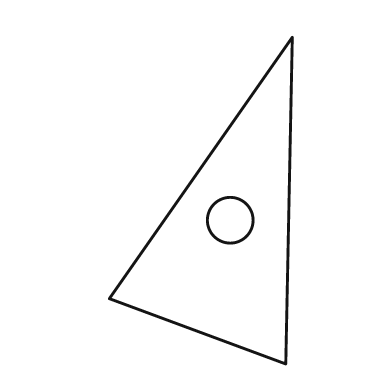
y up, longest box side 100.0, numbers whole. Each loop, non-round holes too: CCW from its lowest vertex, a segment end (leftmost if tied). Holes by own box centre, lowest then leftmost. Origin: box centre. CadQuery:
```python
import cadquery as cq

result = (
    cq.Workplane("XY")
    .moveTo(26.0, -50.0)
    .lineTo(28.0, 50.0)
    .lineTo(-28.0, -30.0)
    .close()
    .moveTo(9.0, -6.0)
    .circle(7.0)
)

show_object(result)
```